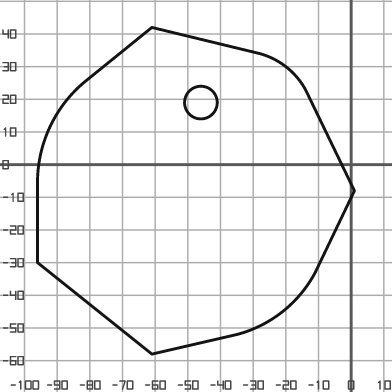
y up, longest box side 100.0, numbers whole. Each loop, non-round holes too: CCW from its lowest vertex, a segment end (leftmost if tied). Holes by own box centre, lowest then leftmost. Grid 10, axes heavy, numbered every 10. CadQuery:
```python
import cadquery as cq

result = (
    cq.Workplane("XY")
    .moveTo(-61.0, -58.0)
    .lineTo(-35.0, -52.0)
    .threePointArc((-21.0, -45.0), (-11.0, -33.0))
    .lineTo(1.0, -8.0)
    .lineTo(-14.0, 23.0)
    .threePointArc((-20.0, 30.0), (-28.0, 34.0))
    .lineTo(-61.0, 42.0)
    .lineTo(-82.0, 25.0)
    .threePointArc((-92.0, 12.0), (-96.0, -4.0))
    .lineTo(-96.0, -30.0)
    .close()
    .moveTo(-46.0, 19.0)
    .circle(5.0)
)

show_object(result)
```